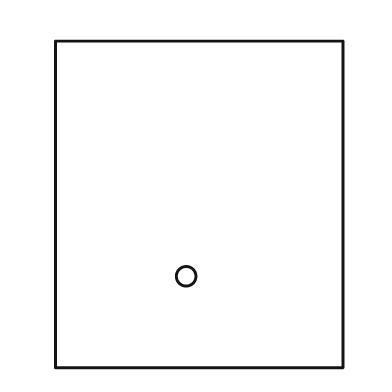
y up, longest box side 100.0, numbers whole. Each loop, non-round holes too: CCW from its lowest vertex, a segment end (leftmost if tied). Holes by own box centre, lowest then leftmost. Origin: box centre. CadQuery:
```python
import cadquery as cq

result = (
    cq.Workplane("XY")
    .moveTo(-44.0, -50.0)
    .lineTo(44.0, -50.0)
    .lineTo(44.0, 50.0)
    .lineTo(-44.0, 50.0)
    .close()
    .moveTo(-4.0, -22.0)
    .circle(3.0)
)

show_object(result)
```